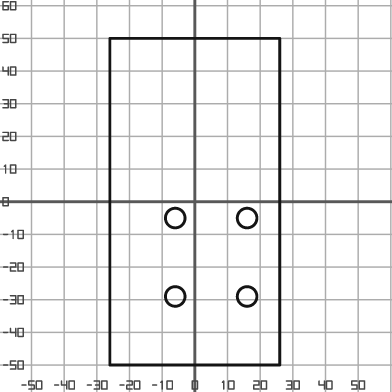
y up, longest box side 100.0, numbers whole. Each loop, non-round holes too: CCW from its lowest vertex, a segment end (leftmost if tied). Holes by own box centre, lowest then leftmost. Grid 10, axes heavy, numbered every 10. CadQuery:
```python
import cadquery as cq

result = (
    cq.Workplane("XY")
    .moveTo(-26.0, -50.0)
    .lineTo(26.0, -50.0)
    .lineTo(26.0, 50.0)
    .lineTo(-26.0, 50.0)
    .close()
    .moveTo(-6.0, -29.0)
    .circle(3.0)
    .moveTo(16.0, -29.0)
    .circle(3.0)
    .moveTo(-6.0, -5.0)
    .circle(3.0)
    .moveTo(16.0, -5.0)
    .circle(3.0)
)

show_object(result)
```